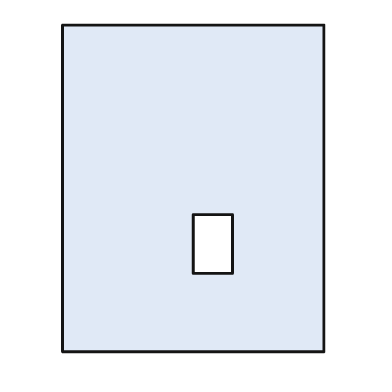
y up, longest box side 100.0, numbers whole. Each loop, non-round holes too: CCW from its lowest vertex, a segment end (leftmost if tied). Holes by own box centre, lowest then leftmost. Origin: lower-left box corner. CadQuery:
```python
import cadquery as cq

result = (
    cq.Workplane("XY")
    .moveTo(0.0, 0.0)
    .lineTo(80.0, 0.0)
    .lineTo(80.0, 100.0)
    .lineTo(0.0, 100.0)
    .close()
    .moveTo(40.0, 24.0)
    .lineTo(52.0, 24.0)
    .lineTo(52.0, 42.0)
    .lineTo(40.0, 42.0)
    .close()
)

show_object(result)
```